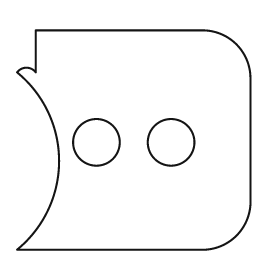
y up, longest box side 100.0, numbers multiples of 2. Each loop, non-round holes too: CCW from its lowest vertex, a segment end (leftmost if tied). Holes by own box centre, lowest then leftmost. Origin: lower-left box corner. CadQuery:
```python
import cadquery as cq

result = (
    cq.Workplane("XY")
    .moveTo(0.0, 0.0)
    .lineTo(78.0, 0.0)
    .threePointArc((94.0, 6.0), (100.0, 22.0))
    .lineTo(100.0, 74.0)
    .threePointArc((94.0, 88.0), (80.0, 94.0))
    .lineTo(8.0, 94.0)
    .lineTo(8.0, 76.0)
    .threePointArc((4.0, 78.0), (0.0, 76.0))
    .threePointArc((18.0, 38.0), (0.0, 0.0))
    .close()
    .moveTo(34.0, 46.0)
    .circle(10.0)
    .moveTo(66.0, 46.0)
    .circle(10.0)
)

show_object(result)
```